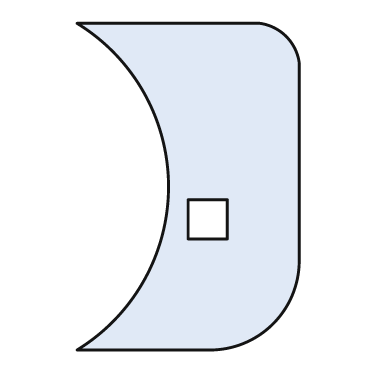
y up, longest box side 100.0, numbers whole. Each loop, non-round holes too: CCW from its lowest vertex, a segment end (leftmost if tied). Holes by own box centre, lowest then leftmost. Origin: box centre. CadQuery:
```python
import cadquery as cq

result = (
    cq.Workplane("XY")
    .moveTo(-34.0, -50.0)
    .lineTo(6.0, -50.0)
    .threePointArc((26.0, -42.0), (34.0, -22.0))
    .lineTo(34.0, 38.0)
    .threePointArc((30.0, 46.0), (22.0, 50.0))
    .lineTo(-34.0, 50.0)
    .threePointArc((-6.0, 0.0), (-34.0, -50.0))
    .close()
    .moveTo(0.0, -16.0)
    .lineTo(12.0, -16.0)
    .lineTo(12.0, -4.0)
    .lineTo(0.0, -4.0)
    .close()
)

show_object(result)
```